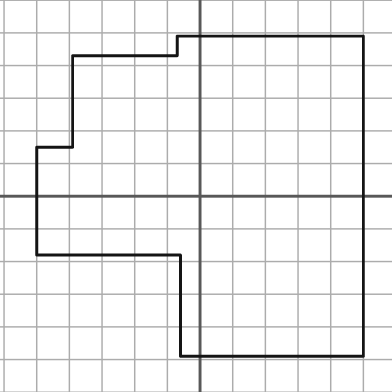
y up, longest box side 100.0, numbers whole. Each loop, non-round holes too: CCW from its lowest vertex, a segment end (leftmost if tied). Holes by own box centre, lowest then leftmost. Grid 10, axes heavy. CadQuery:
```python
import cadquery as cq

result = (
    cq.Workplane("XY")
    .moveTo(-6.0, -49.0)
    .lineTo(50.0, -49.0)
    .lineTo(50.0, 49.0)
    .lineTo(-7.0, 49.0)
    .lineTo(-7.0, 43.0)
    .lineTo(-39.0, 43.0)
    .lineTo(-39.0, 15.0)
    .lineTo(-50.0, 15.0)
    .lineTo(-50.0, -18.0)
    .lineTo(-6.0, -18.0)
    .close()
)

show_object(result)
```